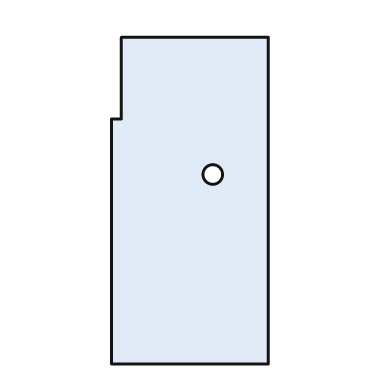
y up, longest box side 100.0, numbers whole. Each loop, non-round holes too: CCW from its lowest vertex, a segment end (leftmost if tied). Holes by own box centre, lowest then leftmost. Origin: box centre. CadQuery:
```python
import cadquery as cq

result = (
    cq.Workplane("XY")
    .moveTo(-24.0, -50.0)
    .lineTo(24.0, -50.0)
    .lineTo(24.0, 50.0)
    .lineTo(-21.0, 50.0)
    .lineTo(-21.0, 25.0)
    .lineTo(-24.0, 25.0)
    .close()
    .moveTo(7.0, 8.0)
    .circle(3.0)
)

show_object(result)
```